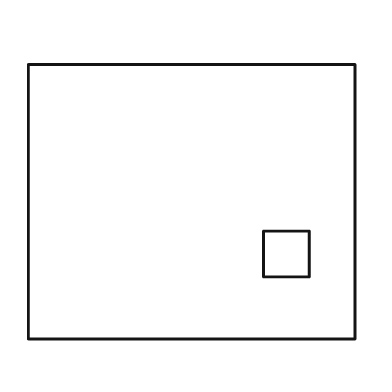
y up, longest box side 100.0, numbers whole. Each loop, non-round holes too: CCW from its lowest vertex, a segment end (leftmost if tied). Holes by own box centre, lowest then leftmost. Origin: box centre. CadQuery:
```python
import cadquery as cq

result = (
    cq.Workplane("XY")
    .moveTo(-50.0, -42.0)
    .lineTo(50.0, -42.0)
    .lineTo(50.0, 42.0)
    .lineTo(-50.0, 42.0)
    .close()
    .moveTo(22.0, -23.0)
    .lineTo(36.0, -23.0)
    .lineTo(36.0, -9.0)
    .lineTo(22.0, -9.0)
    .close()
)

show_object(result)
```